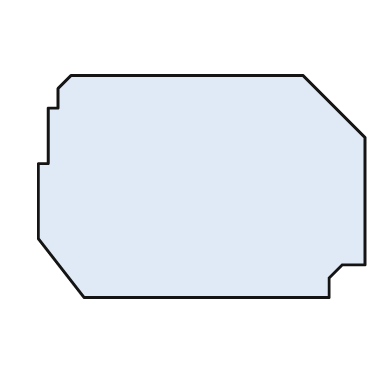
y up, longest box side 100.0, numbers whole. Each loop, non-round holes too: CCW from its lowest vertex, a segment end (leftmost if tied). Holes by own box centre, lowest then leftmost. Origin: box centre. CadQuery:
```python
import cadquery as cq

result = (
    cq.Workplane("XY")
    .moveTo(-36.0, -34.0)
    .lineTo(39.0, -34.0)
    .lineTo(39.0, -28.0)
    .lineTo(43.0, -24.0)
    .lineTo(50.0, -24.0)
    .lineTo(50.0, 15.0)
    .lineTo(31.0, 34.0)
    .lineTo(-40.0, 34.0)
    .lineTo(-44.0, 30.0)
    .lineTo(-44.0, 24.0)
    .lineTo(-47.0, 24.0)
    .lineTo(-47.0, 7.0)
    .lineTo(-50.0, 7.0)
    .lineTo(-50.0, -16.0)
    .close()
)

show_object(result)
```